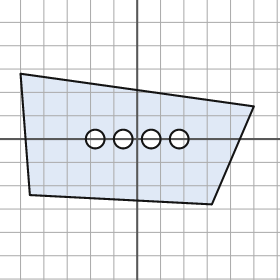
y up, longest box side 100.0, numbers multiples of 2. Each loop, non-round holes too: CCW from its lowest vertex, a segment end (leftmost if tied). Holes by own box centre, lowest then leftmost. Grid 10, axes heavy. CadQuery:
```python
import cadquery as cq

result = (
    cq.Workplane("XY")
    .moveTo(32.0, -28.0)
    .lineTo(50.0, 14.0)
    .lineTo(-50.0, 28.0)
    .lineTo(-46.0, -24.0)
    .close()
    .moveTo(-18.0, 0.0)
    .circle(4.0)
    .moveTo(-6.0, 0.0)
    .circle(4.0)
    .moveTo(6.0, 0.0)
    .circle(4.0)
    .moveTo(18.0, 0.0)
    .circle(4.0)
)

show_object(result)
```